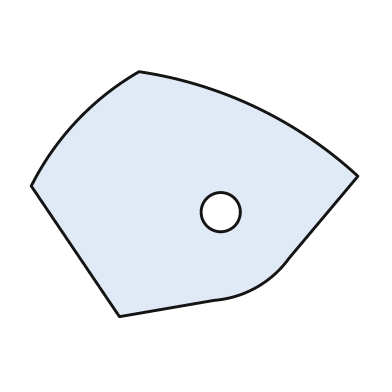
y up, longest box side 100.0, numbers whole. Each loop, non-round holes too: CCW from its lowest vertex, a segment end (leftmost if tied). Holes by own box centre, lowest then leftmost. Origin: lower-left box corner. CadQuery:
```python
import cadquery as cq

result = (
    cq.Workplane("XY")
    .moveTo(27.0, 0.0)
    .lineTo(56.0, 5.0)
    .threePointArc((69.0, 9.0), (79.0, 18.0))
    .lineTo(100.0, 43.0)
    .threePointArc((69.0, 64.0), (33.0, 75.0))
    .threePointArc((14.0, 60.0), (0.0, 40.0))
    .close()
    .moveTo(58.0, 32.0)
    .circle(6.0)
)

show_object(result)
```